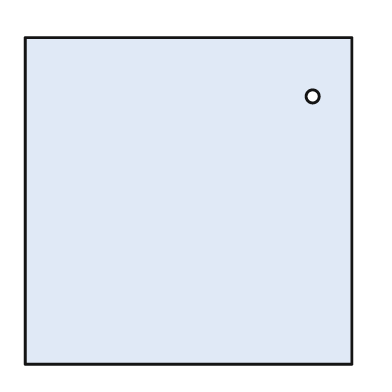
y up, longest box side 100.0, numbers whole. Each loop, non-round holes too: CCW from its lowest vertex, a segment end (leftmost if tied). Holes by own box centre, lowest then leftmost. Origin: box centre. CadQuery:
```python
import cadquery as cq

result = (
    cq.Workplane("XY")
    .moveTo(-50.0, -50.0)
    .lineTo(50.0, -50.0)
    .lineTo(50.0, 50.0)
    .lineTo(-50.0, 50.0)
    .close()
    .moveTo(38.0, 32.0)
    .circle(2.0)
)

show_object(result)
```